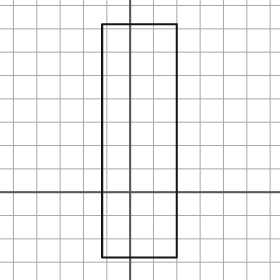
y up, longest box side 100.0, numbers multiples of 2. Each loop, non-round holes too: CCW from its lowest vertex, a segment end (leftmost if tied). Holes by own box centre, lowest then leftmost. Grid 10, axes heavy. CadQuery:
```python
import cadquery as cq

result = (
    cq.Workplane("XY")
    .moveTo(-12.0, -28.0)
    .lineTo(20.0, -28.0)
    .lineTo(20.0, 72.0)
    .lineTo(-12.0, 72.0)
    .close()
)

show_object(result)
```